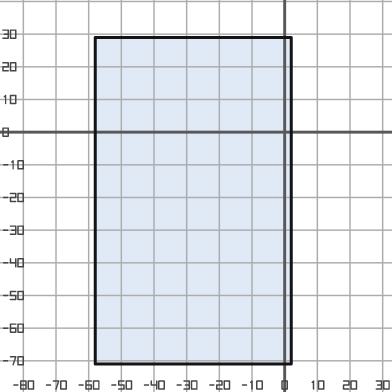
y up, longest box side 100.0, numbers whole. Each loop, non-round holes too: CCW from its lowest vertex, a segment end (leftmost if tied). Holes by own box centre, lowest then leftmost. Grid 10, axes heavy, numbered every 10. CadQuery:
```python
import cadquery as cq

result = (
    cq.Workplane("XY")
    .moveTo(-58.0, -71.0)
    .lineTo(2.0, -71.0)
    .lineTo(2.0, 29.0)
    .lineTo(-58.0, 29.0)
    .close()
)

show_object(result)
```